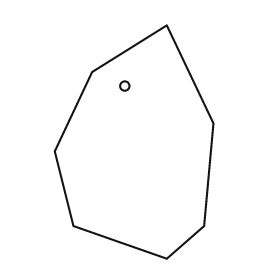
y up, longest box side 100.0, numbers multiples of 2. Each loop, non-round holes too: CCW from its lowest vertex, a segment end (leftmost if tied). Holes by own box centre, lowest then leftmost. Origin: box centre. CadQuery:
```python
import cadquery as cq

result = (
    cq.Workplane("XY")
    .moveTo(14.0, -50.0)
    .lineTo(30.0, -36.0)
    .lineTo(34.0, 8.0)
    .lineTo(14.0, 50.0)
    .lineTo(-18.0, 30.0)
    .lineTo(-34.0, -4.0)
    .lineTo(-26.0, -36.0)
    .close()
    .moveTo(-4.0, 24.0)
    .circle(2.0)
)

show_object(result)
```